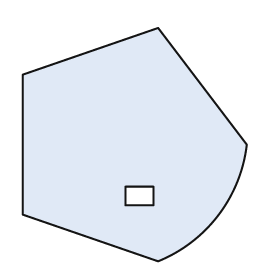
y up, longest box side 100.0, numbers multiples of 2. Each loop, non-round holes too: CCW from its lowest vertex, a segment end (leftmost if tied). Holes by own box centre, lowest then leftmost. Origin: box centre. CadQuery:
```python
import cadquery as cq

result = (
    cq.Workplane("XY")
    .moveTo(10.0, -50.0)
    .threePointArc((36.0, -30.0), (48.0, 0.0))
    .lineTo(10.0, 50.0)
    .lineTo(-48.0, 30.0)
    .lineTo(-48.0, -30.0)
    .close()
    .moveTo(-4.0, -26.0)
    .lineTo(8.0, -26.0)
    .lineTo(8.0, -18.0)
    .lineTo(-4.0, -18.0)
    .close()
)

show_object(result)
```